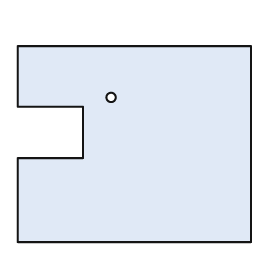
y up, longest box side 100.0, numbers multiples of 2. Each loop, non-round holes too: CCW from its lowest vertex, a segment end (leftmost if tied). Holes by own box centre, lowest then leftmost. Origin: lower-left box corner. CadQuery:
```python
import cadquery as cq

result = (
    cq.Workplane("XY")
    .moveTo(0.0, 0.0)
    .lineTo(100.0, 0.0)
    .lineTo(100.0, 84.0)
    .lineTo(0.0, 84.0)
    .lineTo(0.0, 58.0)
    .lineTo(28.0, 58.0)
    .lineTo(28.0, 36.0)
    .lineTo(0.0, 36.0)
    .close()
    .moveTo(40.0, 62.0)
    .circle(2.0)
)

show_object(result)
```